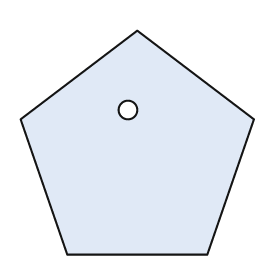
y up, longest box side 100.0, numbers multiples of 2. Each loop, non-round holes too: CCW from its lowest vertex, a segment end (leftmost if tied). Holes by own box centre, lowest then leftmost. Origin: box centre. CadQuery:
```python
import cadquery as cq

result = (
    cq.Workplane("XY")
    .moveTo(-30.0, -48.0)
    .lineTo(30.0, -48.0)
    .lineTo(50.0, 10.0)
    .lineTo(0.0, 48.0)
    .lineTo(-50.0, 10.0)
    .close()
    .moveTo(-4.0, 14.0)
    .circle(4.0)
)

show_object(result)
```